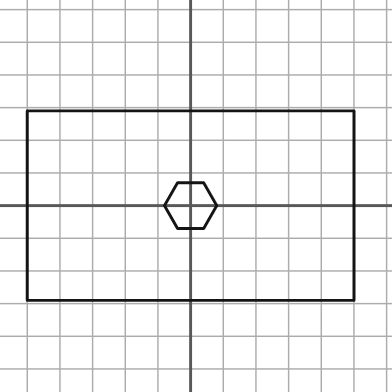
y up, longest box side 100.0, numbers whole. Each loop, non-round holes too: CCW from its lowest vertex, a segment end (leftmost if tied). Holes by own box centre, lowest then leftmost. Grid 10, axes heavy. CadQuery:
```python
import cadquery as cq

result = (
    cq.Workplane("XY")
    .moveTo(-50.0, -29.0)
    .lineTo(50.0, -29.0)
    .lineTo(50.0, 29.0)
    .lineTo(-50.0, 29.0)
    .close()
    .moveTo(-4.0, -7.0)
    .lineTo(4.0, -7.0)
    .lineTo(8.0, 0.0)
    .lineTo(4.0, 7.0)
    .lineTo(-4.0, 7.0)
    .lineTo(-8.0, 0.0)
    .close()
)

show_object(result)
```